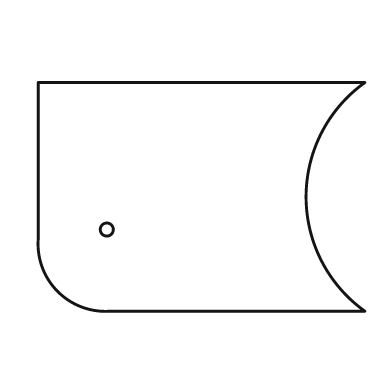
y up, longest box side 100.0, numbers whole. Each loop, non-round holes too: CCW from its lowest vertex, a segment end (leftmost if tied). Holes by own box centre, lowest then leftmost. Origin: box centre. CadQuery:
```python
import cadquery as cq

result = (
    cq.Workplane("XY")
    .moveTo(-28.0, -35.0)
    .lineTo(50.0, -35.0)
    .threePointArc((32.0, 0.0), (50.0, 35.0))
    .lineTo(-50.0, 35.0)
    .lineTo(-50.0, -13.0)
    .threePointArc((-44.0, -29.0), (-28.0, -35.0))
    .close()
    .moveTo(-29.0, -10.0)
    .circle(2.0)
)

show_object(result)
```